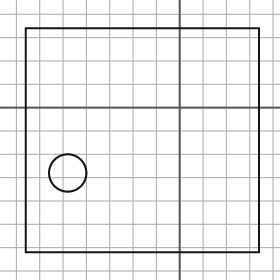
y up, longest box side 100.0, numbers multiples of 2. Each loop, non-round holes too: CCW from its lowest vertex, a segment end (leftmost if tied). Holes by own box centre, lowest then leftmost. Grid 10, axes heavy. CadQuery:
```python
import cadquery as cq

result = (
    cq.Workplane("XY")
    .moveTo(-66.0, -62.0)
    .lineTo(34.0, -62.0)
    .lineTo(34.0, 34.0)
    .lineTo(-66.0, 34.0)
    .close()
    .moveTo(-48.0, -28.0)
    .circle(8.0)
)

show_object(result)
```